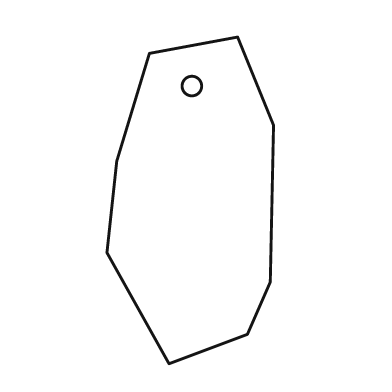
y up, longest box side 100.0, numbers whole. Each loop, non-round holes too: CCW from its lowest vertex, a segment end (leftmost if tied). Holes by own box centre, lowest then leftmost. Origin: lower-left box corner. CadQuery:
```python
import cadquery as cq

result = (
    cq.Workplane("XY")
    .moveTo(19.0, 0.0)
    .lineTo(43.0, 9.0)
    .lineTo(50.0, 25.0)
    .lineTo(51.0, 73.0)
    .lineTo(40.0, 100.0)
    .lineTo(13.0, 95.0)
    .lineTo(3.0, 62.0)
    .lineTo(0.0, 34.0)
    .close()
    .moveTo(26.0, 85.0)
    .circle(3.0)
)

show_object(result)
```